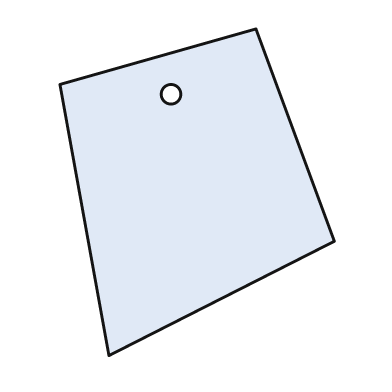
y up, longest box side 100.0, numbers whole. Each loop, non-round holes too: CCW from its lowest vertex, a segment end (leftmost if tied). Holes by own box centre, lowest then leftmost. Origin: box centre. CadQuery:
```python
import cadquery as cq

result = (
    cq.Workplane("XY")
    .moveTo(-27.0, -50.0)
    .lineTo(42.0, -15.0)
    .lineTo(18.0, 50.0)
    .lineTo(-42.0, 33.0)
    .close()
    .moveTo(-8.0, 30.0)
    .circle(3.0)
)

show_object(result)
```